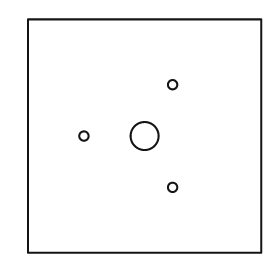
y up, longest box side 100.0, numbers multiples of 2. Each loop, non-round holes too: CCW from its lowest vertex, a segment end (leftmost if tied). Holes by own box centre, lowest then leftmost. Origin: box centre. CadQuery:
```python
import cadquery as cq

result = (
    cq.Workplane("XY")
    .moveTo(-50.0, -50.0)
    .lineTo(50.0, -50.0)
    .lineTo(50.0, 50.0)
    .lineTo(-50.0, 50.0)
    .close()
    .moveTo(12.0, -22.0)
    .circle(2.0)
    .moveTo(-26.0, 0.0)
    .circle(2.0)
    .moveTo(0.0, 0.0)
    .circle(6.0)
    .moveTo(12.0, 22.0)
    .circle(2.0)
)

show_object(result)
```